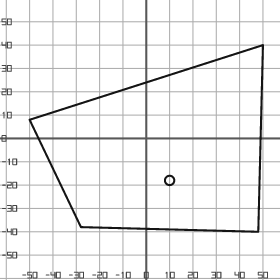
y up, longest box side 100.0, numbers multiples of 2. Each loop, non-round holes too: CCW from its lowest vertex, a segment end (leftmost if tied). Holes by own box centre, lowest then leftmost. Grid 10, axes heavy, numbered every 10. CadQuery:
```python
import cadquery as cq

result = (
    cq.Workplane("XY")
    .moveTo(48.0, -40.0)
    .lineTo(50.0, 40.0)
    .lineTo(-50.0, 8.0)
    .lineTo(-28.0, -38.0)
    .close()
    .moveTo(10.0, -18.0)
    .circle(2.0)
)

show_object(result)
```